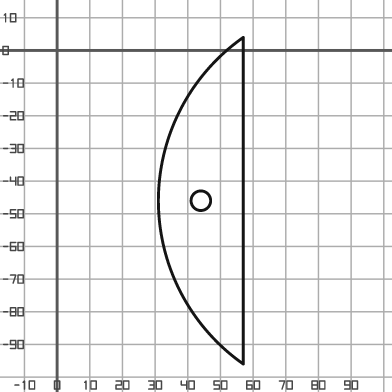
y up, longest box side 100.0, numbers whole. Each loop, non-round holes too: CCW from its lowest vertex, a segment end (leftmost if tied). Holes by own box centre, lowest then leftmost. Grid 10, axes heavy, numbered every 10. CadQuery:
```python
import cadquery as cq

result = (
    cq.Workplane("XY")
    .moveTo(57.0, -96.0)
    .lineTo(57.0, 4.0)
    .threePointArc((31.0, -46.0), (57.0, -96.0))
    .close()
    .moveTo(44.0, -46.0)
    .circle(3.0)
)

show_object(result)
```